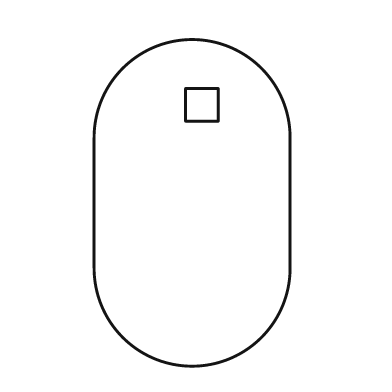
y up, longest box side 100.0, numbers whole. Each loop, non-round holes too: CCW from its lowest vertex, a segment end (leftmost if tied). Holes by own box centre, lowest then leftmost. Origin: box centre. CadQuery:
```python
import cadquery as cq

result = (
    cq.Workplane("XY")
    .moveTo(-30.0, -20.0)
    .threePointArc((0.0, -50.0), (30.0, -20.0))
    .lineTo(30.0, 20.0)
    .threePointArc((0.0, 50.0), (-30.0, 20.0))
    .close()
    .moveTo(-2.0, 25.0)
    .lineTo(8.0, 25.0)
    .lineTo(8.0, 35.0)
    .lineTo(-2.0, 35.0)
    .close()
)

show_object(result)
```